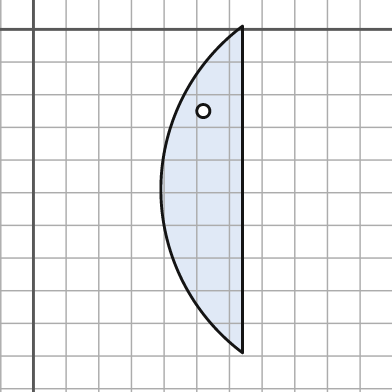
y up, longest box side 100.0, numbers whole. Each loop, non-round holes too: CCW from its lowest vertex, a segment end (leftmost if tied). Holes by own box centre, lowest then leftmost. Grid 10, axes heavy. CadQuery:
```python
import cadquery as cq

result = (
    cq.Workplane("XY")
    .moveTo(64.0, -99.0)
    .lineTo(64.0, 1.0)
    .threePointArc((39.0, -49.0), (64.0, -99.0))
    .close()
    .moveTo(52.0, -25.0)
    .circle(2.0)
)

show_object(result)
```